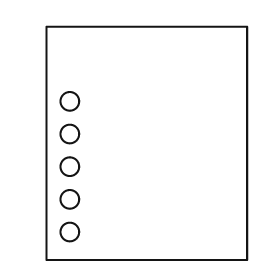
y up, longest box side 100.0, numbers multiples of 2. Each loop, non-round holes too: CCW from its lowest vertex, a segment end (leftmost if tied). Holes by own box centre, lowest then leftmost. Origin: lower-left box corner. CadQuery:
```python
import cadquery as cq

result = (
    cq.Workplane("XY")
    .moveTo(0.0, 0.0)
    .lineTo(86.0, 0.0)
    .lineTo(86.0, 100.0)
    .lineTo(0.0, 100.0)
    .close()
    .moveTo(10.0, 12.0)
    .circle(4.0)
    .moveTo(10.0, 26.0)
    .circle(4.0)
    .moveTo(10.0, 40.0)
    .circle(4.0)
    .moveTo(10.0, 54.0)
    .circle(4.0)
    .moveTo(10.0, 68.0)
    .circle(4.0)
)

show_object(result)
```